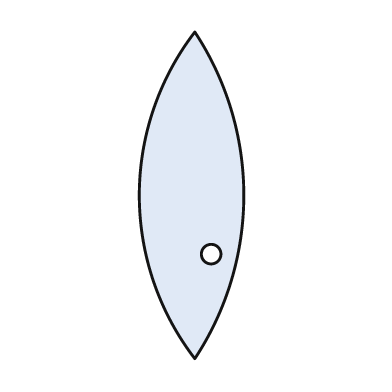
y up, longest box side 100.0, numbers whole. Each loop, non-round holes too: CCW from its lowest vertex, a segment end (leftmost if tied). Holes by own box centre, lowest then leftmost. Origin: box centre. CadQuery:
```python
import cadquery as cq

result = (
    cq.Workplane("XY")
    .moveTo(1.0, -50.0)
    .threePointArc((16.0, 0.0), (1.0, 50.0))
    .threePointArc((-16.0, 0.0), (1.0, -50.0))
    .close()
    .moveTo(6.0, -18.0)
    .circle(3.0)
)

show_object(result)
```